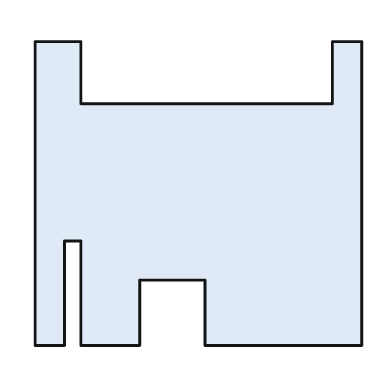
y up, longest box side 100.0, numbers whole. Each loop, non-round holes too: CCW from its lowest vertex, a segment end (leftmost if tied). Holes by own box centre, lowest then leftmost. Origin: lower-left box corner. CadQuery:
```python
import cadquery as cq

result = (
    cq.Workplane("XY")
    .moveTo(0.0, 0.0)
    .lineTo(9.0, 0.0)
    .lineTo(9.0, 32.0)
    .lineTo(14.0, 32.0)
    .lineTo(14.0, 0.0)
    .lineTo(32.0, 0.0)
    .lineTo(32.0, 20.0)
    .lineTo(52.0, 20.0)
    .lineTo(52.0, 0.0)
    .lineTo(100.0, 0.0)
    .lineTo(100.0, 93.0)
    .lineTo(91.0, 93.0)
    .lineTo(91.0, 74.0)
    .lineTo(14.0, 74.0)
    .lineTo(14.0, 93.0)
    .lineTo(0.0, 93.0)
    .close()
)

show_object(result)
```